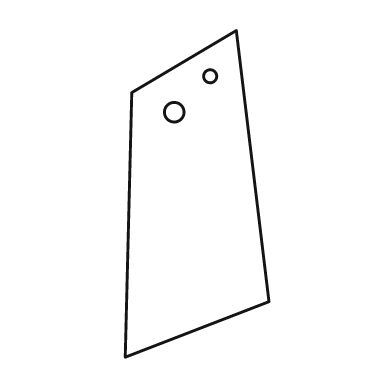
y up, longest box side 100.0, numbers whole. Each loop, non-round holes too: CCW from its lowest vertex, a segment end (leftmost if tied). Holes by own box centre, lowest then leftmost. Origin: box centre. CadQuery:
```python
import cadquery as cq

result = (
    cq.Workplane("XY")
    .moveTo(-22.0, -50.0)
    .lineTo(22.0, -33.0)
    .lineTo(12.0, 50.0)
    .lineTo(-20.0, 31.0)
    .close()
    .moveTo(-7.0, 25.0)
    .circle(3.0)
    .moveTo(4.0, 36.0)
    .circle(2.0)
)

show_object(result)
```